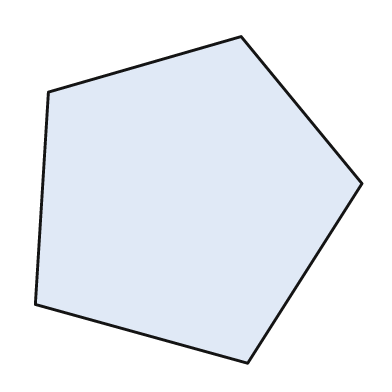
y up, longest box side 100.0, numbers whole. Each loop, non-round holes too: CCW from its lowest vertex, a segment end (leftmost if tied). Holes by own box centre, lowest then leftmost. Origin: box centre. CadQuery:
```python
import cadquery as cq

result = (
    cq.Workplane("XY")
    .moveTo(15.0, -50.0)
    .lineTo(50.0, 5.0)
    .lineTo(13.0, 50.0)
    .lineTo(-46.0, 33.0)
    .lineTo(-50.0, -32.0)
    .close()
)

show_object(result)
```